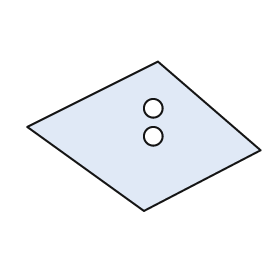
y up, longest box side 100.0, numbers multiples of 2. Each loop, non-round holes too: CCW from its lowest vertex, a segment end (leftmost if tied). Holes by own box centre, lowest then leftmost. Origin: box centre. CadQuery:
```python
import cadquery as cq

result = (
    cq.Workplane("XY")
    .moveTo(0.0, -32.0)
    .lineTo(50.0, -6.0)
    .lineTo(6.0, 32.0)
    .lineTo(-50.0, 4.0)
    .close()
    .moveTo(4.0, 0.0)
    .circle(4.0)
    .moveTo(4.0, 12.0)
    .circle(4.0)
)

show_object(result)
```